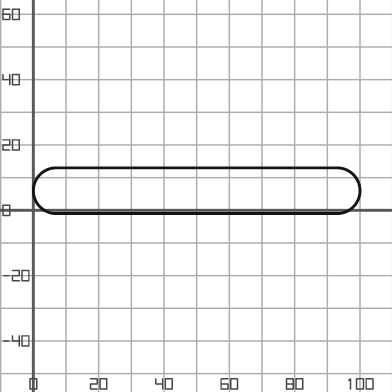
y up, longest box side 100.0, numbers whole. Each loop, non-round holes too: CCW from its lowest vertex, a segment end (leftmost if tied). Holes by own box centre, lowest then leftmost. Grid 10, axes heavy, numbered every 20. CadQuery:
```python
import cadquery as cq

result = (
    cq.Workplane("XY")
    .moveTo(7.0, -1.0)
    .lineTo(93.0, -1.0)
    .threePointArc((100.0, 6.0), (93.0, 13.0))
    .lineTo(7.0, 13.0)
    .threePointArc((0.0, 6.0), (7.0, -1.0))
    .close()
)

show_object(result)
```